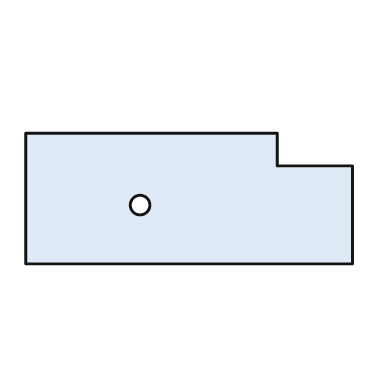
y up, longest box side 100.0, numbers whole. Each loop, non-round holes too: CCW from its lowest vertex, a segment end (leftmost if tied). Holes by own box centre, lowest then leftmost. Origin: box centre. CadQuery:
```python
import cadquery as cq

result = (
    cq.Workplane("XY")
    .moveTo(-50.0, -20.0)
    .lineTo(50.0, -20.0)
    .lineTo(50.0, 10.0)
    .lineTo(27.0, 10.0)
    .lineTo(27.0, 20.0)
    .lineTo(-50.0, 20.0)
    .close()
    .moveTo(-15.0, -2.0)
    .circle(3.0)
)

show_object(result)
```